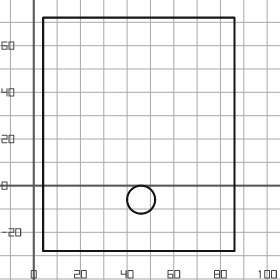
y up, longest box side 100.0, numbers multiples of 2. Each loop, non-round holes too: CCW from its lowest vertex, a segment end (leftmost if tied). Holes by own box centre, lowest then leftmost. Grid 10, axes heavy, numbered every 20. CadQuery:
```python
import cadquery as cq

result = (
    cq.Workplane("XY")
    .moveTo(4.0, -28.0)
    .lineTo(86.0, -28.0)
    .lineTo(86.0, 72.0)
    .lineTo(4.0, 72.0)
    .close()
    .moveTo(46.0, -6.0)
    .circle(6.0)
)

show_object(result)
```